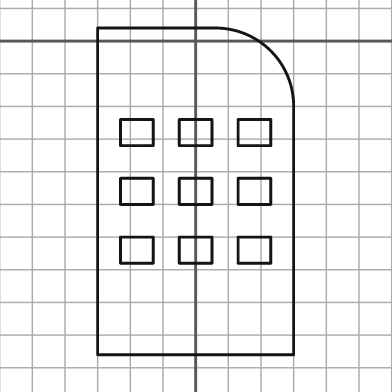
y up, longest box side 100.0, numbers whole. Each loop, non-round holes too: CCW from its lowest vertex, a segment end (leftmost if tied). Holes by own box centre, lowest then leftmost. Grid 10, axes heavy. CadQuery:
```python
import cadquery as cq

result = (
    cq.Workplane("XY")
    .moveTo(-30.0, -96.0)
    .lineTo(30.0, -96.0)
    .lineTo(30.0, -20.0)
    .threePointArc((23.0, -3.0), (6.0, 4.0))
    .lineTo(-30.0, 4.0)
    .close()
    .moveTo(-23.0, -68.0)
    .lineTo(-13.0, -68.0)
    .lineTo(-13.0, -60.0)
    .lineTo(-23.0, -60.0)
    .close()
    .moveTo(-5.0, -68.0)
    .lineTo(5.0, -68.0)
    .lineTo(5.0, -60.0)
    .lineTo(-5.0, -60.0)
    .close()
    .moveTo(13.0, -68.0)
    .lineTo(23.0, -68.0)
    .lineTo(23.0, -60.0)
    .lineTo(13.0, -60.0)
    .close()
    .moveTo(-23.0, -50.0)
    .lineTo(-13.0, -50.0)
    .lineTo(-13.0, -42.0)
    .lineTo(-23.0, -42.0)
    .close()
    .moveTo(-5.0, -50.0)
    .lineTo(5.0, -50.0)
    .lineTo(5.0, -42.0)
    .lineTo(-5.0, -42.0)
    .close()
    .moveTo(13.0, -50.0)
    .lineTo(23.0, -50.0)
    .lineTo(23.0, -42.0)
    .lineTo(13.0, -42.0)
    .close()
    .moveTo(-23.0, -32.0)
    .lineTo(-13.0, -32.0)
    .lineTo(-13.0, -24.0)
    .lineTo(-23.0, -24.0)
    .close()
    .moveTo(-5.0, -32.0)
    .lineTo(5.0, -32.0)
    .lineTo(5.0, -24.0)
    .lineTo(-5.0, -24.0)
    .close()
    .moveTo(13.0, -32.0)
    .lineTo(23.0, -32.0)
    .lineTo(23.0, -24.0)
    .lineTo(13.0, -24.0)
    .close()
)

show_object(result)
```